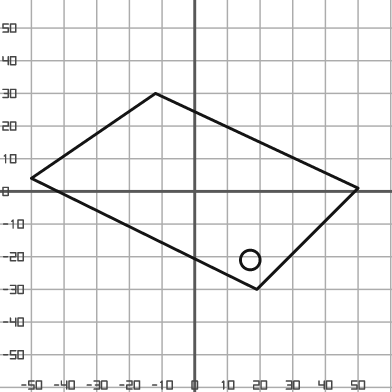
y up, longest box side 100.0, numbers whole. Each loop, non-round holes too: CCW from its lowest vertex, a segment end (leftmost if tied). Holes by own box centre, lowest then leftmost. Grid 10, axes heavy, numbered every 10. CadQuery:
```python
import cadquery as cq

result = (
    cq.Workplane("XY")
    .moveTo(19.0, -30.0)
    .lineTo(50.0, 1.0)
    .lineTo(-12.0, 30.0)
    .lineTo(-50.0, 4.0)
    .close()
    .moveTo(17.0, -21.0)
    .circle(3.0)
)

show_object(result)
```